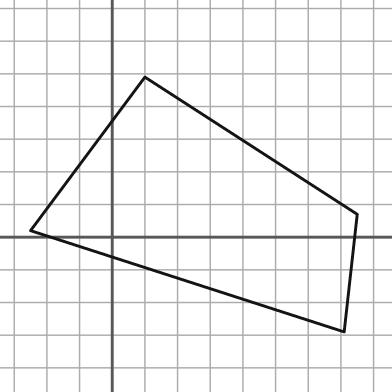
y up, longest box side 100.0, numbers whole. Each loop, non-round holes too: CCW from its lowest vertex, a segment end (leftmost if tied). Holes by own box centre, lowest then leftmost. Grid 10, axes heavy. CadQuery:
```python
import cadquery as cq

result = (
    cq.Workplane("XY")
    .moveTo(71.0, -29.0)
    .lineTo(75.0, 7.0)
    .lineTo(10.0, 49.0)
    .lineTo(-25.0, 2.0)
    .close()
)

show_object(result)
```